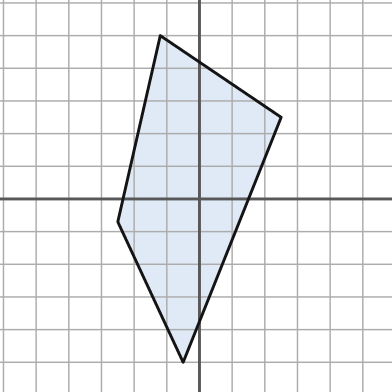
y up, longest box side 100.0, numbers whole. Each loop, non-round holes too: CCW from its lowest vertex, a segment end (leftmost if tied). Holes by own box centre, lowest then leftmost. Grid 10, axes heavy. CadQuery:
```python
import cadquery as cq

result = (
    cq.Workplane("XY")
    .moveTo(-5.0, -50.0)
    .lineTo(25.0, 25.0)
    .lineTo(-12.0, 50.0)
    .lineTo(-25.0, -7.0)
    .close()
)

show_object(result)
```